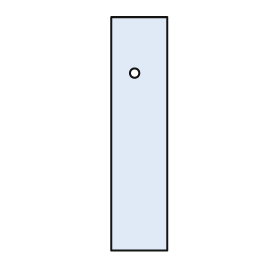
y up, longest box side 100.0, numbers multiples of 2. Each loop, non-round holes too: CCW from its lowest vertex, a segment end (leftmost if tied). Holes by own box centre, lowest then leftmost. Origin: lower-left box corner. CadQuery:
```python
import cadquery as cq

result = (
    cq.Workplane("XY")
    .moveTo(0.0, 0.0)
    .lineTo(24.0, 0.0)
    .lineTo(24.0, 100.0)
    .lineTo(0.0, 100.0)
    .close()
    .moveTo(10.0, 76.0)
    .circle(2.0)
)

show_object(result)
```